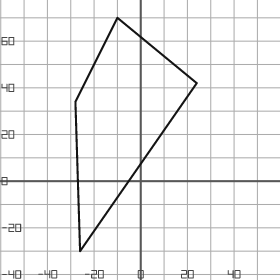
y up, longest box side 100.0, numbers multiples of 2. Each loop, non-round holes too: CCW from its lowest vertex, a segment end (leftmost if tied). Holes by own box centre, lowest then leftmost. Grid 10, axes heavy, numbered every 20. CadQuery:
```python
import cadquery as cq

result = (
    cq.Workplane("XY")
    .moveTo(-26.0, -30.0)
    .lineTo(24.0, 42.0)
    .lineTo(-10.0, 70.0)
    .lineTo(-28.0, 34.0)
    .close()
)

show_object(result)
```